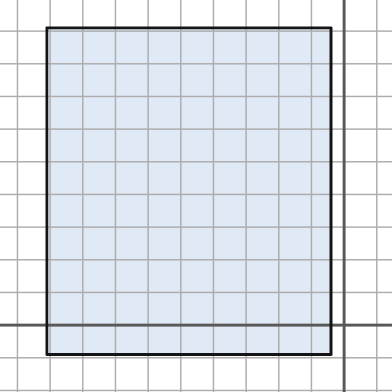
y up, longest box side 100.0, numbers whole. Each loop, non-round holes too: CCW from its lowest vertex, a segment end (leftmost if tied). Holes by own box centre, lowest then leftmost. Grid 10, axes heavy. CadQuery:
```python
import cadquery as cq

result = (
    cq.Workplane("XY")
    .moveTo(-91.0, -9.0)
    .lineTo(-4.0, -9.0)
    .lineTo(-4.0, 91.0)
    .lineTo(-91.0, 91.0)
    .close()
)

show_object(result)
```